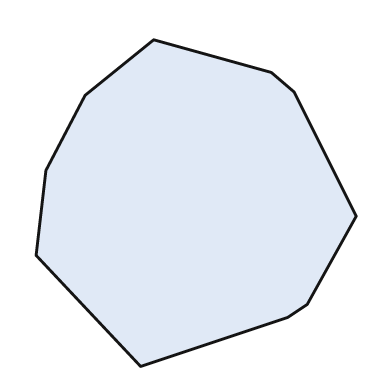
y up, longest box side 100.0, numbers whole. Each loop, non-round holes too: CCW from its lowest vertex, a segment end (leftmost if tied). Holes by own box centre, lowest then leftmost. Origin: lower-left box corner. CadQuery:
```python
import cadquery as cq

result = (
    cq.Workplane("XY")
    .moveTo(32.0, 0.0)
    .lineTo(77.0, 15.0)
    .lineTo(83.0, 19.0)
    .lineTo(98.0, 46.0)
    .lineTo(79.0, 84.0)
    .lineTo(72.0, 90.0)
    .lineTo(36.0, 100.0)
    .lineTo(15.0, 83.0)
    .lineTo(3.0, 60.0)
    .lineTo(0.0, 34.0)
    .close()
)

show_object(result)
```